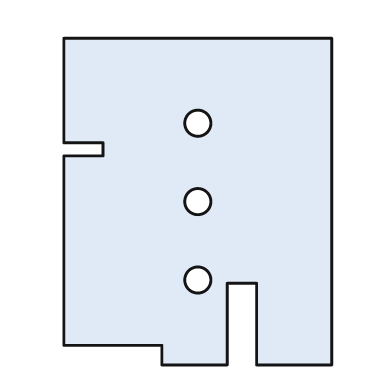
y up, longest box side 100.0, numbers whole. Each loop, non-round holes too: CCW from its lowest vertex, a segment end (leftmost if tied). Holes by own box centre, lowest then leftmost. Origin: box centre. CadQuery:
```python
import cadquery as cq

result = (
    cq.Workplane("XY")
    .moveTo(-11.0, -50.0)
    .lineTo(9.0, -50.0)
    .lineTo(9.0, -25.0)
    .lineTo(18.0, -25.0)
    .lineTo(18.0, -50.0)
    .lineTo(41.0, -50.0)
    .lineTo(41.0, 50.0)
    .lineTo(-41.0, 50.0)
    .lineTo(-41.0, 18.0)
    .lineTo(-29.0, 18.0)
    .lineTo(-29.0, 14.0)
    .lineTo(-41.0, 14.0)
    .lineTo(-41.0, -44.0)
    .lineTo(-11.0, -44.0)
    .close()
    .moveTo(0.0, -24.0)
    .circle(4.0)
    .moveTo(0.0, 0.0)
    .circle(4.0)
    .moveTo(0.0, 24.0)
    .circle(4.0)
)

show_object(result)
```